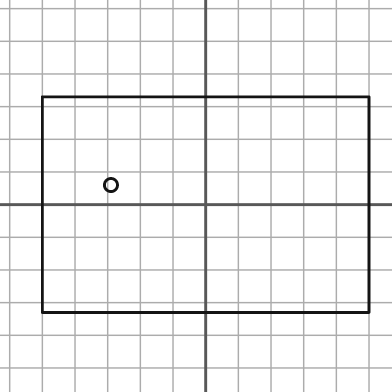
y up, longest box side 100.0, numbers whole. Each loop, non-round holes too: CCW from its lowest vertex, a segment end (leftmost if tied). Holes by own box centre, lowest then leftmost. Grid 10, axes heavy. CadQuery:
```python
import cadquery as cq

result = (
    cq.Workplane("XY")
    .moveTo(-50.0, -33.0)
    .lineTo(50.0, -33.0)
    .lineTo(50.0, 33.0)
    .lineTo(-50.0, 33.0)
    .close()
    .moveTo(-29.0, 6.0)
    .circle(2.0)
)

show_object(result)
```